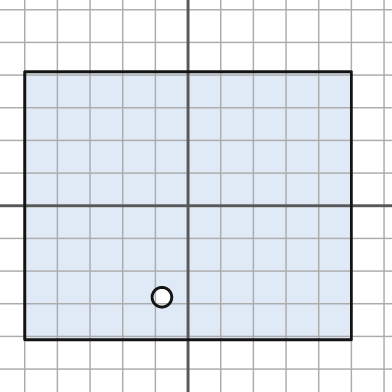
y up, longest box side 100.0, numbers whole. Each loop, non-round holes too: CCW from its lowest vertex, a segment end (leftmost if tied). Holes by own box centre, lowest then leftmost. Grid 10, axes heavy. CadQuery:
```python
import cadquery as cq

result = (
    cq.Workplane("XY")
    .moveTo(-50.0, -41.0)
    .lineTo(50.0, -41.0)
    .lineTo(50.0, 41.0)
    .lineTo(-50.0, 41.0)
    .close()
    .moveTo(-8.0, -28.0)
    .circle(3.0)
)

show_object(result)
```